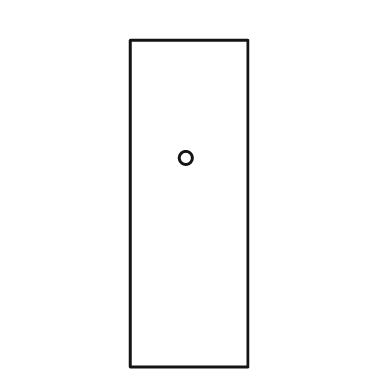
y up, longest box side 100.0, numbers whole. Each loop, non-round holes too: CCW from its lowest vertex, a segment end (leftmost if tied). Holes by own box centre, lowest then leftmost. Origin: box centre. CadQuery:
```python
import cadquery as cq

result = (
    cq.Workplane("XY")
    .moveTo(-18.0, -50.0)
    .lineTo(18.0, -50.0)
    .lineTo(18.0, 50.0)
    .lineTo(-18.0, 50.0)
    .close()
    .moveTo(-1.0, 14.0)
    .circle(2.0)
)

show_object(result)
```